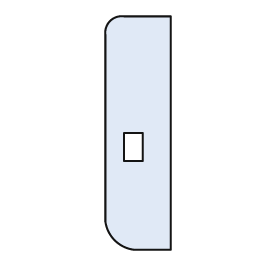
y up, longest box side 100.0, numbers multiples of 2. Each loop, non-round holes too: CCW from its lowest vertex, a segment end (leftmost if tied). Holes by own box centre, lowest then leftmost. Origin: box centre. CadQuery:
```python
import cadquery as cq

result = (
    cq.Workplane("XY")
    .moveTo(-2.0, -50.0)
    .lineTo(14.0, -50.0)
    .lineTo(14.0, 50.0)
    .lineTo(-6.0, 50.0)
    .threePointArc((-12.0, 48.0), (-14.0, 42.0))
    .lineTo(-14.0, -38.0)
    .threePointArc((-10.0, -46.0), (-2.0, -50.0))
    .close()
    .moveTo(-6.0, -12.0)
    .lineTo(2.0, -12.0)
    .lineTo(2.0, 0.0)
    .lineTo(-6.0, 0.0)
    .close()
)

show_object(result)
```